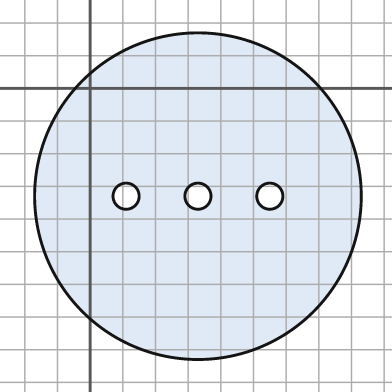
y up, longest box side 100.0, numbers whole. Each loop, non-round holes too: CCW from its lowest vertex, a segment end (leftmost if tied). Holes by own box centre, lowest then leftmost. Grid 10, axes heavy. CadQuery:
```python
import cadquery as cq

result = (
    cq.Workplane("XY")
    .moveTo(33.0, -33.0)
    .circle(50.0)
    .moveTo(11.0, -33.0)
    .circle(4.0)
    .moveTo(33.0, -33.0)
    .circle(4.0)
    .moveTo(55.0, -33.0)
    .circle(4.0)
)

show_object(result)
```